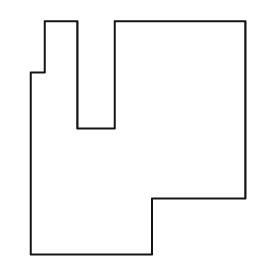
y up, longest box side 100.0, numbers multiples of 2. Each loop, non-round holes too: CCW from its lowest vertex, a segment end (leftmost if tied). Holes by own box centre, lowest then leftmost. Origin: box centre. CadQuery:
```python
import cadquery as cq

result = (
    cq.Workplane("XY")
    .moveTo(-46.0, -50.0)
    .lineTo(6.0, -50.0)
    .lineTo(6.0, -26.0)
    .lineTo(46.0, -26.0)
    .lineTo(46.0, 50.0)
    .lineTo(-10.0, 50.0)
    .lineTo(-10.0, 4.0)
    .lineTo(-26.0, 4.0)
    .lineTo(-26.0, 50.0)
    .lineTo(-40.0, 50.0)
    .lineTo(-40.0, 28.0)
    .lineTo(-46.0, 28.0)
    .close()
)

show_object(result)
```